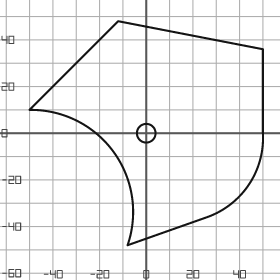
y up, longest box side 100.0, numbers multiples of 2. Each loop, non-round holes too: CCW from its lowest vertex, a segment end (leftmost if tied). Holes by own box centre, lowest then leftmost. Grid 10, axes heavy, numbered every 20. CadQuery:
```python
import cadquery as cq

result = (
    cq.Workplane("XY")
    .moveTo(-8.0, -48.0)
    .lineTo(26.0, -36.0)
    .threePointArc((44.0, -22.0), (50.0, 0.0))
    .lineTo(50.0, 36.0)
    .lineTo(-12.0, 48.0)
    .lineTo(-50.0, 10.0)
    .threePointArc((-14.0, -8.0), (-8.0, -48.0))
    .close()
    .moveTo(0.0, 0.0)
    .circle(4.0)
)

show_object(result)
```